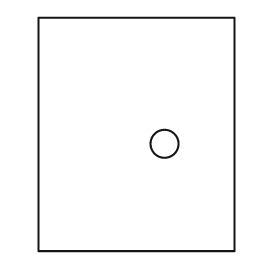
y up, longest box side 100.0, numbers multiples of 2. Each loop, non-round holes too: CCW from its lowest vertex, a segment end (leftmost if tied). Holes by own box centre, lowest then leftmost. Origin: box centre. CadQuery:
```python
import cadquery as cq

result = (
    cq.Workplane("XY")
    .moveTo(-42.0, -50.0)
    .lineTo(42.0, -50.0)
    .lineTo(42.0, 50.0)
    .lineTo(-42.0, 50.0)
    .close()
    .moveTo(12.0, -4.0)
    .circle(6.0)
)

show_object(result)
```